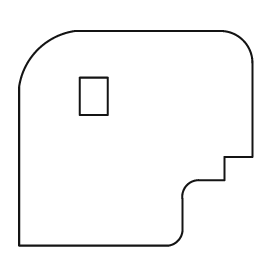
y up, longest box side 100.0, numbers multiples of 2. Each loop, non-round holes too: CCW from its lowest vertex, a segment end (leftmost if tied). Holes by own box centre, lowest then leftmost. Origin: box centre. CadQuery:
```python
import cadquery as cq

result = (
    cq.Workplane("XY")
    .moveTo(-50.0, -46.0)
    .lineTo(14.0, -46.0)
    .threePointArc((18.0, -44.0), (20.0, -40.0))
    .lineTo(20.0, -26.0)
    .threePointArc((22.0, -20.0), (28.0, -18.0))
    .lineTo(38.0, -18.0)
    .lineTo(38.0, -8.0)
    .lineTo(50.0, -8.0)
    .lineTo(50.0, 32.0)
    .threePointArc((46.0, 42.0), (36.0, 46.0))
    .lineTo(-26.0, 46.0)
    .threePointArc((-42.0, 38.0), (-50.0, 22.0))
    .close()
    .moveTo(-24.0, 10.0)
    .lineTo(-12.0, 10.0)
    .lineTo(-12.0, 26.0)
    .lineTo(-24.0, 26.0)
    .close()
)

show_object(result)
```